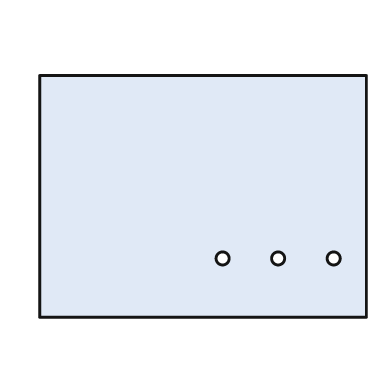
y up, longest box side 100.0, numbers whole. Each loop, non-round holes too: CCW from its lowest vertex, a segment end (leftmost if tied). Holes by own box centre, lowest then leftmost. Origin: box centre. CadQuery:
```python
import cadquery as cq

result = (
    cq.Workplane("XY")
    .moveTo(-50.0, -37.0)
    .lineTo(50.0, -37.0)
    .lineTo(50.0, 37.0)
    .lineTo(-50.0, 37.0)
    .close()
    .moveTo(6.0, -19.0)
    .circle(2.0)
    .moveTo(23.0, -19.0)
    .circle(2.0)
    .moveTo(40.0, -19.0)
    .circle(2.0)
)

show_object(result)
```